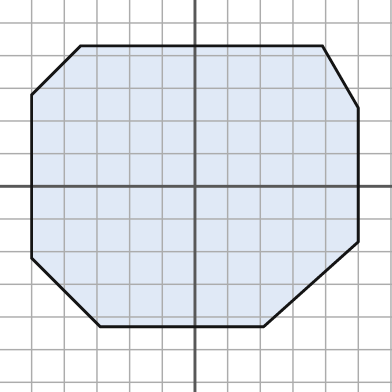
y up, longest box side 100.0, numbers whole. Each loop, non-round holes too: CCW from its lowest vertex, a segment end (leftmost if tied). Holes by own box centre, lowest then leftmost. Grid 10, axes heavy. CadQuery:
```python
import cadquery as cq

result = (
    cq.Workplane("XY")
    .moveTo(-29.0, -43.0)
    .lineTo(21.0, -43.0)
    .lineTo(50.0, -17.0)
    .lineTo(50.0, 24.0)
    .lineTo(39.0, 43.0)
    .lineTo(-35.0, 43.0)
    .lineTo(-50.0, 28.0)
    .lineTo(-50.0, -22.0)
    .close()
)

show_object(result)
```